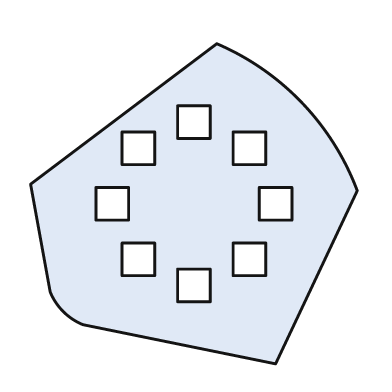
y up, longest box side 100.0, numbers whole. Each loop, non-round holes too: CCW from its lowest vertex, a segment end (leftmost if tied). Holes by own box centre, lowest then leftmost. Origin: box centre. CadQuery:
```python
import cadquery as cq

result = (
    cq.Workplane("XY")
    .moveTo(25.0, -49.0)
    .lineTo(50.0, 4.0)
    .threePointArc((33.0, 31.0), (7.0, 49.0))
    .lineTo(-50.0, 6.0)
    .lineTo(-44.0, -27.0)
    .threePointArc((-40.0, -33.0), (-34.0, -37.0))
    .close()
    .moveTo(-5.0, -30.0)
    .lineTo(5.0, -30.0)
    .lineTo(5.0, -20.0)
    .lineTo(-5.0, -20.0)
    .close()
    .moveTo(-22.0, -22.0)
    .lineTo(-12.0, -22.0)
    .lineTo(-12.0, -12.0)
    .lineTo(-22.0, -12.0)
    .close()
    .moveTo(12.0, -22.0)
    .lineTo(22.0, -22.0)
    .lineTo(22.0, -12.0)
    .lineTo(12.0, -12.0)
    .close()
    .moveTo(-30.0, -5.0)
    .lineTo(-20.0, -5.0)
    .lineTo(-20.0, 5.0)
    .lineTo(-30.0, 5.0)
    .close()
    .moveTo(20.0, -5.0)
    .lineTo(30.0, -5.0)
    .lineTo(30.0, 5.0)
    .lineTo(20.0, 5.0)
    .close()
    .moveTo(-22.0, 12.0)
    .lineTo(-12.0, 12.0)
    .lineTo(-12.0, 22.0)
    .lineTo(-22.0, 22.0)
    .close()
    .moveTo(12.0, 12.0)
    .lineTo(22.0, 12.0)
    .lineTo(22.0, 22.0)
    .lineTo(12.0, 22.0)
    .close()
    .moveTo(-5.0, 20.0)
    .lineTo(5.0, 20.0)
    .lineTo(5.0, 30.0)
    .lineTo(-5.0, 30.0)
    .close()
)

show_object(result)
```